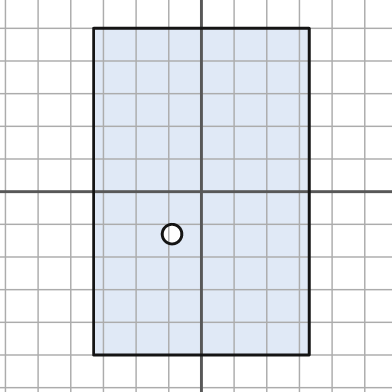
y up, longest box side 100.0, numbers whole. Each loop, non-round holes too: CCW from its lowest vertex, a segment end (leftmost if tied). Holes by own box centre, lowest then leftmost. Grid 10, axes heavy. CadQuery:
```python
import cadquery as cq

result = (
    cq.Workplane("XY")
    .moveTo(-33.0, -50.0)
    .lineTo(33.0, -50.0)
    .lineTo(33.0, 50.0)
    .lineTo(-33.0, 50.0)
    .close()
    .moveTo(-9.0, -13.0)
    .circle(3.0)
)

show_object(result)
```